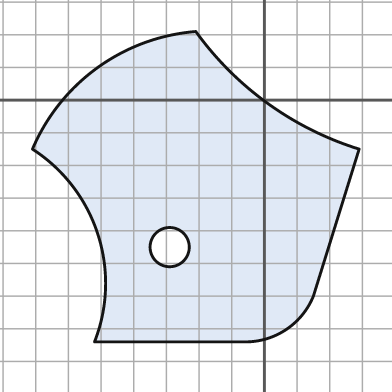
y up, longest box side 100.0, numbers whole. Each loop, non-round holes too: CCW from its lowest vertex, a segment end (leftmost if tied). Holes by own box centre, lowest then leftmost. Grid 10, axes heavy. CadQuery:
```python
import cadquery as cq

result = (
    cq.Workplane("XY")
    .moveTo(-52.0, -74.0)
    .lineTo(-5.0, -74.0)
    .threePointArc((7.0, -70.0), (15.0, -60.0))
    .lineTo(29.0, -15.0)
    .threePointArc((1.0, -1.0), (-21.0, 21.0))
    .threePointArc((-51.0, 10.0), (-71.0, -15.0))
    .threePointArc((-51.0, -41.0), (-52.0, -74.0))
    .close()
    .moveTo(-29.0, -45.0)
    .circle(6.0)
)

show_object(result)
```